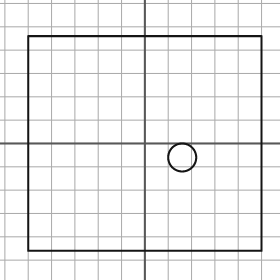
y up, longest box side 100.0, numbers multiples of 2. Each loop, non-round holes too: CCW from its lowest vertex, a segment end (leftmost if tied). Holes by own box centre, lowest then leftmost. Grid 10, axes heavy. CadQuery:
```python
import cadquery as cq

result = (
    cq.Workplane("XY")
    .moveTo(-50.0, -46.0)
    .lineTo(50.0, -46.0)
    .lineTo(50.0, 46.0)
    .lineTo(-50.0, 46.0)
    .close()
    .moveTo(16.0, -6.0)
    .circle(6.0)
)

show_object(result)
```